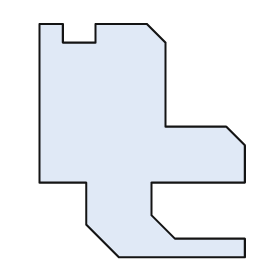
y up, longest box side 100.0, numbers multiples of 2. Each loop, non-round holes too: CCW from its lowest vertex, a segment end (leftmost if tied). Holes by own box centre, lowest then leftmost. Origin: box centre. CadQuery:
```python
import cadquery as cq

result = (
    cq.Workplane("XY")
    .moveTo(-10.0, -50.0)
    .lineTo(44.0, -50.0)
    .lineTo(44.0, -42.0)
    .lineTo(14.0, -42.0)
    .lineTo(4.0, -32.0)
    .lineTo(4.0, -18.0)
    .lineTo(44.0, -18.0)
    .lineTo(44.0, -2.0)
    .lineTo(36.0, 6.0)
    .lineTo(10.0, 6.0)
    .lineTo(10.0, 42.0)
    .lineTo(2.0, 50.0)
    .lineTo(-20.0, 50.0)
    .lineTo(-20.0, 42.0)
    .lineTo(-34.0, 42.0)
    .lineTo(-34.0, 50.0)
    .lineTo(-44.0, 50.0)
    .lineTo(-44.0, -18.0)
    .lineTo(-24.0, -18.0)
    .lineTo(-24.0, -36.0)
    .close()
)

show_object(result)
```